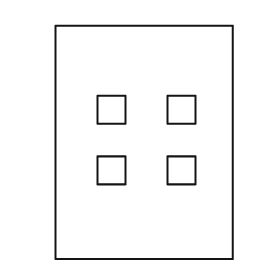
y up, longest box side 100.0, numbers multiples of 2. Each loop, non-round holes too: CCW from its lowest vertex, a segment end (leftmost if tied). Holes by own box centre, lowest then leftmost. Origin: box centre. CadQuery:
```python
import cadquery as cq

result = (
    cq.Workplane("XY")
    .moveTo(-38.0, -50.0)
    .lineTo(38.0, -50.0)
    .lineTo(38.0, 50.0)
    .lineTo(-38.0, 50.0)
    .close()
    .moveTo(-20.0, -18.0)
    .lineTo(-8.0, -18.0)
    .lineTo(-8.0, -6.0)
    .lineTo(-20.0, -6.0)
    .close()
    .moveTo(10.0, -18.0)
    .lineTo(22.0, -18.0)
    .lineTo(22.0, -6.0)
    .lineTo(10.0, -6.0)
    .close()
    .moveTo(-20.0, 8.0)
    .lineTo(-8.0, 8.0)
    .lineTo(-8.0, 20.0)
    .lineTo(-20.0, 20.0)
    .close()
    .moveTo(10.0, 8.0)
    .lineTo(22.0, 8.0)
    .lineTo(22.0, 20.0)
    .lineTo(10.0, 20.0)
    .close()
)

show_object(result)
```